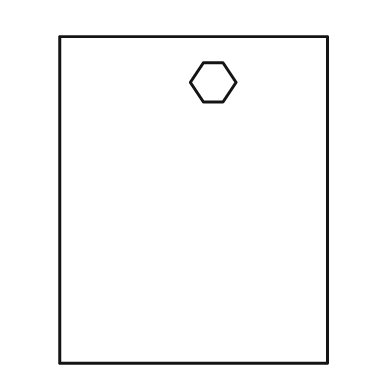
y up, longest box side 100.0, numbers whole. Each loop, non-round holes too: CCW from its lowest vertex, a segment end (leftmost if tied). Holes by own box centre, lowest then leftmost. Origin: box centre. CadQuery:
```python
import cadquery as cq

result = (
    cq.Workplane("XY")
    .moveTo(-41.0, -50.0)
    .lineTo(41.0, -50.0)
    .lineTo(41.0, 50.0)
    .lineTo(-41.0, 50.0)
    .close()
    .moveTo(3.0, 30.0)
    .lineTo(9.0, 30.0)
    .lineTo(13.0, 36.0)
    .lineTo(9.0, 42.0)
    .lineTo(3.0, 42.0)
    .lineTo(-1.0, 36.0)
    .close()
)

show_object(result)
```